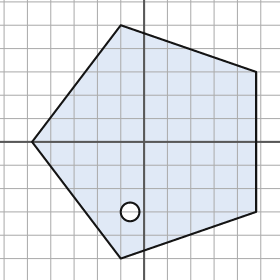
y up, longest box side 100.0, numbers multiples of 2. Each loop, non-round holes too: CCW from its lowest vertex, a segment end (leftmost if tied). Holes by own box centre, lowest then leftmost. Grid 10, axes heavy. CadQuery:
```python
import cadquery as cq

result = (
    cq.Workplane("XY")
    .moveTo(-10.0, -50.0)
    .lineTo(48.0, -30.0)
    .lineTo(48.0, 30.0)
    .lineTo(-10.0, 50.0)
    .lineTo(-48.0, 0.0)
    .close()
    .moveTo(-6.0, -30.0)
    .circle(4.0)
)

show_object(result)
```